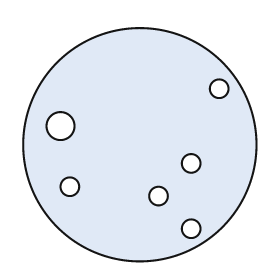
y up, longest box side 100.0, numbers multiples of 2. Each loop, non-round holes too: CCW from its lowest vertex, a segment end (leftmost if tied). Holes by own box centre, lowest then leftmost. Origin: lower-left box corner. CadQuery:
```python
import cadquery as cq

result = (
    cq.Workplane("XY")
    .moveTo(50.0, 50.0)
    .circle(50.0)
    .moveTo(72.0, 14.0)
    .circle(4.0)
    .moveTo(58.0, 28.0)
    .circle(4.0)
    .moveTo(20.0, 32.0)
    .circle(4.0)
    .moveTo(72.0, 42.0)
    .circle(4.0)
    .moveTo(16.0, 58.0)
    .circle(6.0)
    .moveTo(84.0, 74.0)
    .circle(4.0)
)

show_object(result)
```